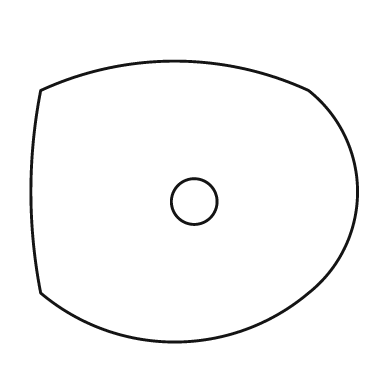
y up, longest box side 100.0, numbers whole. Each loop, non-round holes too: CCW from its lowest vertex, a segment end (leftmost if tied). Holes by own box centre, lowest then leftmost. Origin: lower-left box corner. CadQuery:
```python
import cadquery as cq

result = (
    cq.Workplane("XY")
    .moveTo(3.0, 15.0)
    .threePointArc((44.0, 0.0), (85.0, 15.0))
    .threePointArc((100.0, 46.0), (85.0, 77.0))
    .threePointArc((44.0, 86.0), (3.0, 77.0))
    .threePointArc((0.0, 46.0), (3.0, 15.0))
    .close()
    .moveTo(50.0, 43.0)
    .circle(7.0)
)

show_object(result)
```